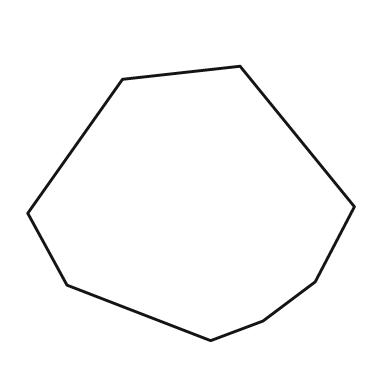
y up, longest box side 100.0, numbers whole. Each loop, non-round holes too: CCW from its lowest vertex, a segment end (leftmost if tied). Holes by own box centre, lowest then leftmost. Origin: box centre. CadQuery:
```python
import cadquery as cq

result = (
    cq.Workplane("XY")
    .moveTo(6.0, -42.0)
    .lineTo(22.0, -36.0)
    .lineTo(38.0, -24.0)
    .lineTo(50.0, -1.0)
    .lineTo(15.0, 42.0)
    .lineTo(-21.0, 38.0)
    .lineTo(-50.0, -3.0)
    .lineTo(-38.0, -25.0)
    .close()
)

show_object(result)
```